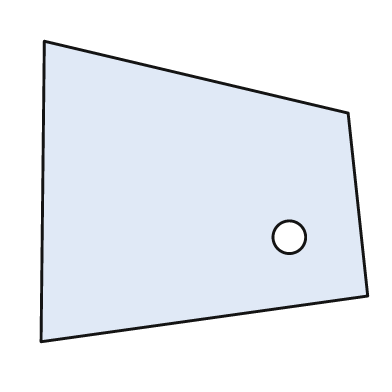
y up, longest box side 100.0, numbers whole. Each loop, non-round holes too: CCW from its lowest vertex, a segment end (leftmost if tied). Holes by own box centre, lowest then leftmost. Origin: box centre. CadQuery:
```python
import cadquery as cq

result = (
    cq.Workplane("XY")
    .moveTo(-50.0, -46.0)
    .lineTo(50.0, -32.0)
    .lineTo(44.0, 24.0)
    .lineTo(-49.0, 46.0)
    .close()
    .moveTo(26.0, -14.0)
    .circle(5.0)
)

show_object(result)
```